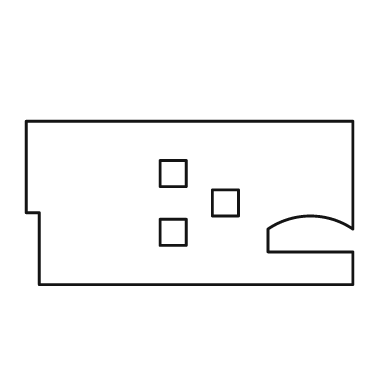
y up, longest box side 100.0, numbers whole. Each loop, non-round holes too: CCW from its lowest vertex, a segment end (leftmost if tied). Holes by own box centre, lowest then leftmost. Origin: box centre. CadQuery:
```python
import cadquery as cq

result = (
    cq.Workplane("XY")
    .moveTo(-46.0, -25.0)
    .lineTo(50.0, -25.0)
    .lineTo(50.0, -15.0)
    .lineTo(24.0, -15.0)
    .lineTo(24.0, -8.0)
    .threePointArc((37.0, -4.0), (50.0, -8.0))
    .lineTo(50.0, 25.0)
    .lineTo(-50.0, 25.0)
    .lineTo(-50.0, -3.0)
    .lineTo(-46.0, -3.0)
    .close()
    .moveTo(-9.0, -13.0)
    .lineTo(-1.0, -13.0)
    .lineTo(-1.0, -5.0)
    .lineTo(-9.0, -5.0)
    .close()
    .moveTo(7.0, -4.0)
    .lineTo(15.0, -4.0)
    .lineTo(15.0, 4.0)
    .lineTo(7.0, 4.0)
    .close()
    .moveTo(-9.0, 5.0)
    .lineTo(-1.0, 5.0)
    .lineTo(-1.0, 13.0)
    .lineTo(-9.0, 13.0)
    .close()
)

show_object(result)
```